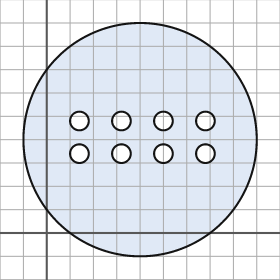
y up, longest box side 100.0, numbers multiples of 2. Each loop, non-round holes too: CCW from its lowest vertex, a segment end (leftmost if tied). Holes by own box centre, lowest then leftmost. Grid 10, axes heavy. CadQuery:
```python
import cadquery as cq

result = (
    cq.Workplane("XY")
    .moveTo(40.0, 40.0)
    .circle(50.0)
    .moveTo(14.0, 34.0)
    .circle(4.0)
    .moveTo(32.0, 34.0)
    .circle(4.0)
    .moveTo(50.0, 34.0)
    .circle(4.0)
    .moveTo(68.0, 34.0)
    .circle(4.0)
    .moveTo(14.0, 48.0)
    .circle(4.0)
    .moveTo(32.0, 48.0)
    .circle(4.0)
    .moveTo(50.0, 48.0)
    .circle(4.0)
    .moveTo(68.0, 48.0)
    .circle(4.0)
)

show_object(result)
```